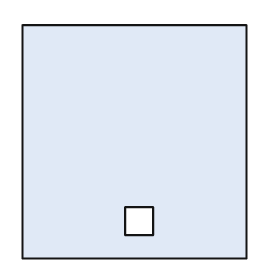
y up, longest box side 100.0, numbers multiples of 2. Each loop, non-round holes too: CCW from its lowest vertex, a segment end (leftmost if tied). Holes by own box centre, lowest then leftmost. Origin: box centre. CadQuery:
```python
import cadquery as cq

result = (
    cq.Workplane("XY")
    .moveTo(-48.0, -50.0)
    .lineTo(48.0, -50.0)
    .lineTo(48.0, 50.0)
    .lineTo(-48.0, 50.0)
    .close()
    .moveTo(-4.0, -40.0)
    .lineTo(8.0, -40.0)
    .lineTo(8.0, -28.0)
    .lineTo(-4.0, -28.0)
    .close()
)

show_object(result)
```